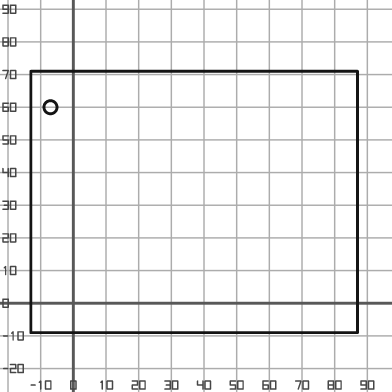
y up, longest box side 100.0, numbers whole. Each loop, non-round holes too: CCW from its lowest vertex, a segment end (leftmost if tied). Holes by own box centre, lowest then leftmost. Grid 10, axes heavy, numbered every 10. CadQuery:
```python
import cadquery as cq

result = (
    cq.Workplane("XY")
    .moveTo(-13.0, -9.0)
    .lineTo(87.0, -9.0)
    .lineTo(87.0, 71.0)
    .lineTo(-13.0, 71.0)
    .close()
    .moveTo(-7.0, 60.0)
    .circle(2.0)
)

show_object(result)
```